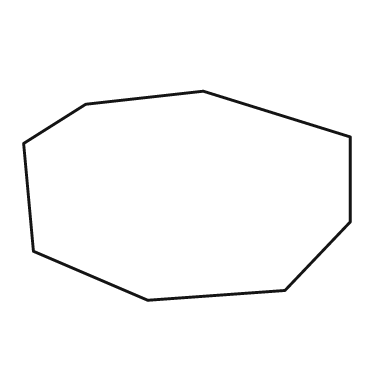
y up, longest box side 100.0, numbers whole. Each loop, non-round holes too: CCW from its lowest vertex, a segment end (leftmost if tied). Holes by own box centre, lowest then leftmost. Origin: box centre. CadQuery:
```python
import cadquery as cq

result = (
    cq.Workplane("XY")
    .moveTo(-12.0, -32.0)
    .lineTo(30.0, -29.0)
    .lineTo(50.0, -8.0)
    .lineTo(50.0, 18.0)
    .lineTo(5.0, 32.0)
    .lineTo(-31.0, 28.0)
    .lineTo(-50.0, 16.0)
    .lineTo(-47.0, -17.0)
    .close()
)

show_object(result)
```